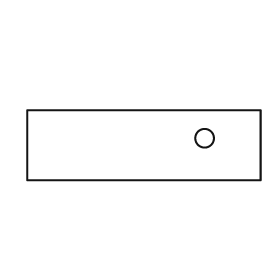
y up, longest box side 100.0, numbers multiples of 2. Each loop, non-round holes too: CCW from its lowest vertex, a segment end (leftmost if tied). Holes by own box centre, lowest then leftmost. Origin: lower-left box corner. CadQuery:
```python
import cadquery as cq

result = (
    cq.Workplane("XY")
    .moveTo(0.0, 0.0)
    .lineTo(100.0, 0.0)
    .lineTo(100.0, 30.0)
    .lineTo(0.0, 30.0)
    .close()
    .moveTo(76.0, 18.0)
    .circle(4.0)
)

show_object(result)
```